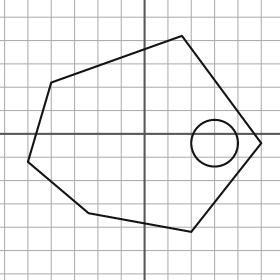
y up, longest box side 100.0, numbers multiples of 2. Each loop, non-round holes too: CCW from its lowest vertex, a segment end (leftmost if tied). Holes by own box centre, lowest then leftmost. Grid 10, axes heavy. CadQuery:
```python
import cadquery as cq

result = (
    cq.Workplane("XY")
    .moveTo(20.0, -42.0)
    .lineTo(50.0, -4.0)
    .lineTo(16.0, 42.0)
    .lineTo(-40.0, 22.0)
    .lineTo(-50.0, -12.0)
    .lineTo(-24.0, -34.0)
    .close()
    .moveTo(30.0, -4.0)
    .circle(10.0)
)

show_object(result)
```